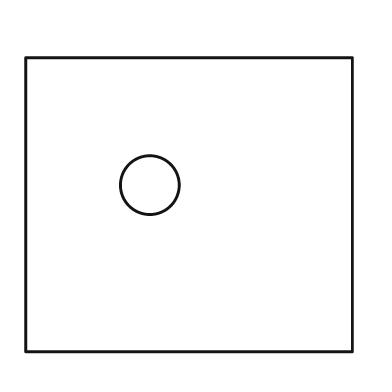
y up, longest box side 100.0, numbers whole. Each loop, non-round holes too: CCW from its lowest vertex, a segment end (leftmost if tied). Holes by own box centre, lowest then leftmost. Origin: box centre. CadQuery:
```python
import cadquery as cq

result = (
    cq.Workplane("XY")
    .moveTo(-50.0, -45.0)
    .lineTo(50.0, -45.0)
    .lineTo(50.0, 45.0)
    .lineTo(-50.0, 45.0)
    .close()
    .moveTo(-12.0, 6.0)
    .circle(9.0)
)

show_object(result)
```